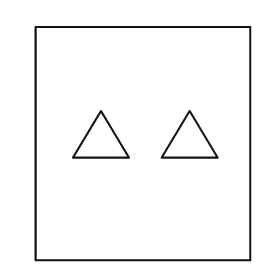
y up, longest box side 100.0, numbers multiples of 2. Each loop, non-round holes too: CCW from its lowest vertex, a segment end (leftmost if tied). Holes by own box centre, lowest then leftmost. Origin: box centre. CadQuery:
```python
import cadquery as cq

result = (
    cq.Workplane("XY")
    .moveTo(-46.0, -50.0)
    .lineTo(46.0, -50.0)
    .lineTo(46.0, 50.0)
    .lineTo(-46.0, 50.0)
    .close()
    .moveTo(-30.0, -6.0)
    .lineTo(-6.0, -6.0)
    .lineTo(-18.0, 14.0)
    .close()
    .moveTo(8.0, -6.0)
    .lineTo(32.0, -6.0)
    .lineTo(20.0, 14.0)
    .close()
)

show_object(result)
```